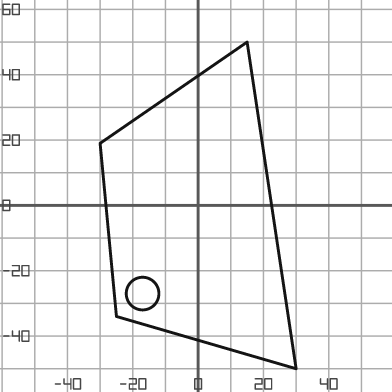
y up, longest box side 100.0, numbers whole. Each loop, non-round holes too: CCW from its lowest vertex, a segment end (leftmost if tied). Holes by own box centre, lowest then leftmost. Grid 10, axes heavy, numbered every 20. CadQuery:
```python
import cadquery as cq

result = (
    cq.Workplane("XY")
    .moveTo(30.0, -50.0)
    .lineTo(15.0, 50.0)
    .lineTo(-30.0, 19.0)
    .lineTo(-25.0, -34.0)
    .close()
    .moveTo(-17.0, -27.0)
    .circle(5.0)
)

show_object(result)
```